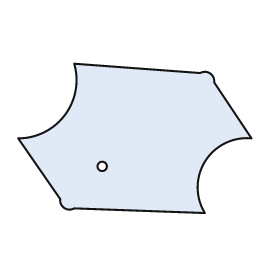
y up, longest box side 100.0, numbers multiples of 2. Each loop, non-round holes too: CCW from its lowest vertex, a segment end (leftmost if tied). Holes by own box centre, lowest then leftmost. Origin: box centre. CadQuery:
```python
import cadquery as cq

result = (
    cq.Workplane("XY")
    .moveTo(30.0, -32.0)
    .threePointArc((30.0, -10.0), (50.0, 0.0))
    .lineTo(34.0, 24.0)
    .threePointArc((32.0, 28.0), (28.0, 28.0))
    .lineTo(-26.0, 32.0)
    .threePointArc((-30.0, 10.0), (-50.0, 0.0))
    .lineTo(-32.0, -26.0)
    .threePointArc((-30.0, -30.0), (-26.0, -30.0))
    .close()
    .moveTo(-14.0, -12.0)
    .circle(2.0)
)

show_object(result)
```